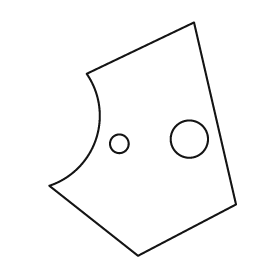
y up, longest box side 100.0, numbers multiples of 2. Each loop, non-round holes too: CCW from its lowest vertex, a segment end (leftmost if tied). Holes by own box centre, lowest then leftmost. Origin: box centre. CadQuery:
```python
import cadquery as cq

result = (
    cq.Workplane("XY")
    .moveTo(-2.0, -50.0)
    .lineTo(40.0, -28.0)
    .lineTo(22.0, 50.0)
    .lineTo(-24.0, 28.0)
    .threePointArc((-20.0, 0.0), (-40.0, -20.0))
    .close()
    .moveTo(-10.0, -2.0)
    .circle(4.0)
    .moveTo(20.0, 0.0)
    .circle(8.0)
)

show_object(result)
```